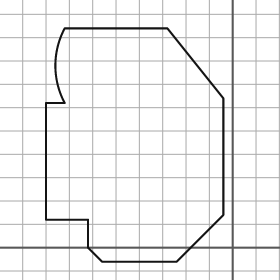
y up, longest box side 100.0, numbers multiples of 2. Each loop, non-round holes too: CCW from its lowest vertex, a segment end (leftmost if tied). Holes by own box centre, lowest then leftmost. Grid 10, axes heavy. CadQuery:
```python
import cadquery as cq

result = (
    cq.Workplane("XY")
    .moveTo(-56.0, -6.0)
    .lineTo(-24.0, -6.0)
    .lineTo(-4.0, 14.0)
    .lineTo(-4.0, 64.0)
    .lineTo(-28.0, 94.0)
    .lineTo(-72.0, 94.0)
    .threePointArc((-76.0, 78.0), (-72.0, 62.0))
    .lineTo(-80.0, 62.0)
    .lineTo(-80.0, 12.0)
    .lineTo(-62.0, 12.0)
    .lineTo(-62.0, 0.0)
    .close()
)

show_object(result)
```